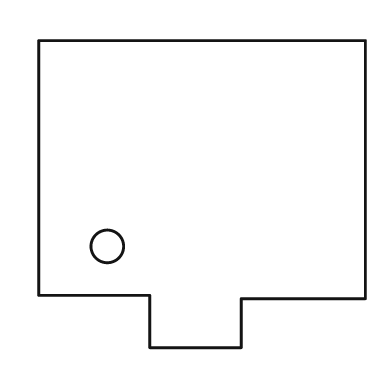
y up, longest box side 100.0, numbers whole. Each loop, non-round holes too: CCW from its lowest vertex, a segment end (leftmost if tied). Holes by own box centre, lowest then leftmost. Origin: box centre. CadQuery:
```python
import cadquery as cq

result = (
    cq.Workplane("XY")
    .moveTo(-16.0, -47.0)
    .lineTo(12.0, -47.0)
    .lineTo(12.0, -32.0)
    .lineTo(50.0, -32.0)
    .lineTo(50.0, 47.0)
    .lineTo(-50.0, 47.0)
    .lineTo(-50.0, -31.0)
    .lineTo(-16.0, -31.0)
    .close()
    .moveTo(-29.0, -16.0)
    .circle(5.0)
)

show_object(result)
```